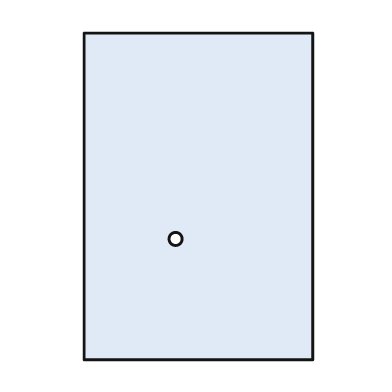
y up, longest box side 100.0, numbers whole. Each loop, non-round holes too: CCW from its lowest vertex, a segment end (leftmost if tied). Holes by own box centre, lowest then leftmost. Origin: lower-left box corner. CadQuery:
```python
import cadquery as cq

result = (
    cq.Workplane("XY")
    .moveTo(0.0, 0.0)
    .lineTo(70.0, 0.0)
    .lineTo(70.0, 100.0)
    .lineTo(0.0, 100.0)
    .close()
    .moveTo(28.0, 37.0)
    .circle(2.0)
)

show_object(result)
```